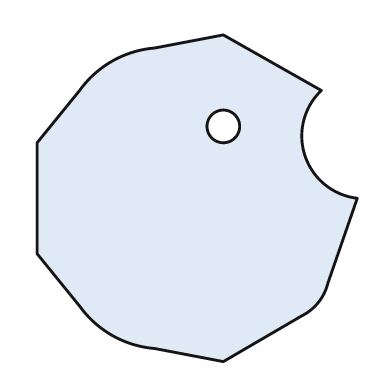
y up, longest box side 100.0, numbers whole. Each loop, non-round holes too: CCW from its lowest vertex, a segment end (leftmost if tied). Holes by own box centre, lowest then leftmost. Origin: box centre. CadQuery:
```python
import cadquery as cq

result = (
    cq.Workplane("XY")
    .moveTo(8.0, -50.0)
    .lineTo(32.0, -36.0)
    .threePointArc((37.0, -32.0), (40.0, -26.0))
    .lineTo(49.0, 0.0)
    .threePointArc((33.0, 13.0), (38.0, 33.0))
    .lineTo(8.0, 50.0)
    .lineTo(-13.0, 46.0)
    .threePointArc((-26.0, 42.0), (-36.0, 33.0))
    .lineTo(-49.0, 17.0)
    .lineTo(-49.0, -17.0)
    .lineTo(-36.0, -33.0)
    .threePointArc((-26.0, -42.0), (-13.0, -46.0))
    .close()
    .moveTo(8.0, 22.0)
    .circle(5.0)
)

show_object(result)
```